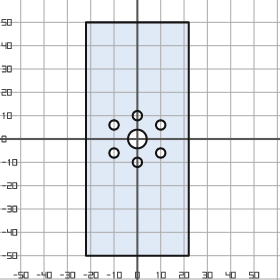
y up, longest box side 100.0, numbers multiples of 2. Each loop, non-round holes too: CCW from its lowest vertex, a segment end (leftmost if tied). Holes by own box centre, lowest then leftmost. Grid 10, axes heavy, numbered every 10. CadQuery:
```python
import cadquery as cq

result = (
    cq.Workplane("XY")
    .moveTo(-22.0, -50.0)
    .lineTo(22.0, -50.0)
    .lineTo(22.0, 50.0)
    .lineTo(-22.0, 50.0)
    .close()
    .moveTo(0.0, -10.0)
    .circle(2.0)
    .moveTo(-10.0, -6.0)
    .circle(2.0)
    .moveTo(10.0, -6.0)
    .circle(2.0)
    .moveTo(0.0, 0.0)
    .circle(4.0)
    .moveTo(-10.0, 6.0)
    .circle(2.0)
    .moveTo(10.0, 6.0)
    .circle(2.0)
    .moveTo(0.0, 10.0)
    .circle(2.0)
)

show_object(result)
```